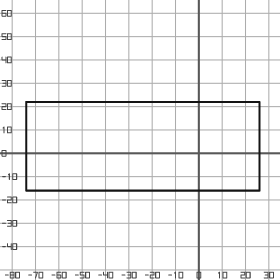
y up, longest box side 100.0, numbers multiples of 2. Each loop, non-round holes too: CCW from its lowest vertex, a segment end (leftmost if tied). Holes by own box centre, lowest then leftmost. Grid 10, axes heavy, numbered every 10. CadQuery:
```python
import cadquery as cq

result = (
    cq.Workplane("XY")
    .moveTo(-74.0, -16.0)
    .lineTo(26.0, -16.0)
    .lineTo(26.0, 22.0)
    .lineTo(-74.0, 22.0)
    .close()
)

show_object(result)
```